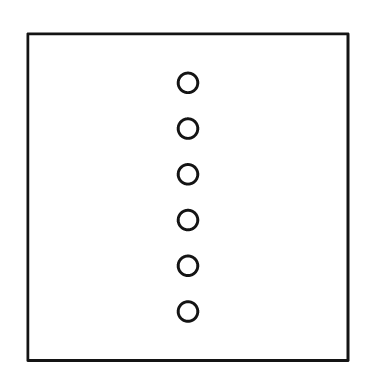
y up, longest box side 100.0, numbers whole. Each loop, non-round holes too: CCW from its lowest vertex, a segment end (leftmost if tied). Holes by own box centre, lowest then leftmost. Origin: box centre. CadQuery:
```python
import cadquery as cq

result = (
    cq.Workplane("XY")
    .moveTo(-49.0, -50.0)
    .lineTo(49.0, -50.0)
    .lineTo(49.0, 50.0)
    .lineTo(-49.0, 50.0)
    .close()
    .moveTo(0.0, -35.0)
    .circle(3.0)
    .moveTo(0.0, -21.0)
    .circle(3.0)
    .moveTo(0.0, -7.0)
    .circle(3.0)
    .moveTo(0.0, 7.0)
    .circle(3.0)
    .moveTo(0.0, 21.0)
    .circle(3.0)
    .moveTo(0.0, 35.0)
    .circle(3.0)
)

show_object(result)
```